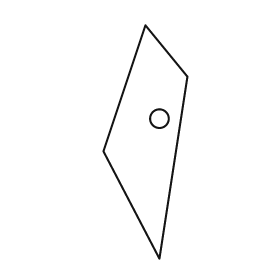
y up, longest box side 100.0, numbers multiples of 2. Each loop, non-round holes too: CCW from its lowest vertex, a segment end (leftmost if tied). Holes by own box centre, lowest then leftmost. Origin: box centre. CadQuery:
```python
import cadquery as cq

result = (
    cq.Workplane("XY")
    .moveTo(6.0, -50.0)
    .lineTo(18.0, 28.0)
    .lineTo(0.0, 50.0)
    .lineTo(-18.0, -4.0)
    .close()
    .moveTo(6.0, 10.0)
    .circle(4.0)
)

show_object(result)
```